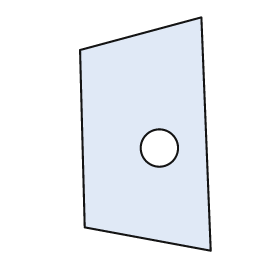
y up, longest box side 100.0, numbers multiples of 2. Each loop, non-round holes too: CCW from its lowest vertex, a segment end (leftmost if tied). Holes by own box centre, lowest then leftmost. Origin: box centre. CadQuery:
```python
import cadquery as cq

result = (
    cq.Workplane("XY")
    .moveTo(28.0, -50.0)
    .lineTo(24.0, 50.0)
    .lineTo(-28.0, 36.0)
    .lineTo(-26.0, -40.0)
    .close()
    .moveTo(6.0, -6.0)
    .circle(8.0)
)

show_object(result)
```